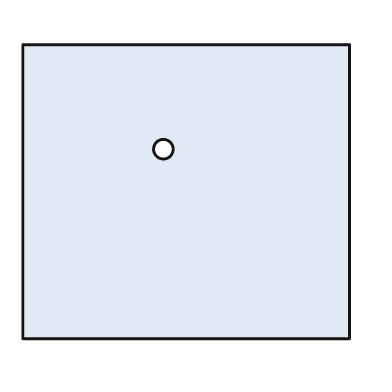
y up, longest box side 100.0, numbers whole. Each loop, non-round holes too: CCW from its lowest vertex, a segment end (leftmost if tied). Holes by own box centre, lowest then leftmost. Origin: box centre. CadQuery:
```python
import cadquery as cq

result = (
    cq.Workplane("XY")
    .moveTo(-50.0, -45.0)
    .lineTo(50.0, -45.0)
    .lineTo(50.0, 45.0)
    .lineTo(-50.0, 45.0)
    .close()
    .moveTo(-7.0, 13.0)
    .circle(3.0)
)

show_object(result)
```